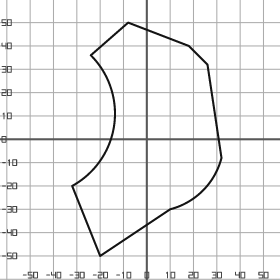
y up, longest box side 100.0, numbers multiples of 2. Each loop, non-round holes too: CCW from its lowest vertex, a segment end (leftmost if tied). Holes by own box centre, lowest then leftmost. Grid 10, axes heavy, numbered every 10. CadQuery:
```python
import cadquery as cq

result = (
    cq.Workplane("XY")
    .moveTo(-20.0, -50.0)
    .lineTo(10.0, -30.0)
    .threePointArc((24.0, -22.0), (32.0, -8.0))
    .lineTo(26.0, 32.0)
    .lineTo(18.0, 40.0)
    .lineTo(-8.0, 50.0)
    .lineTo(-24.0, 36.0)
    .threePointArc((-14.0, 6.0), (-32.0, -20.0))
    .close()
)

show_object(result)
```